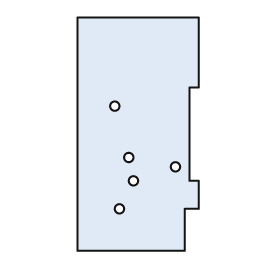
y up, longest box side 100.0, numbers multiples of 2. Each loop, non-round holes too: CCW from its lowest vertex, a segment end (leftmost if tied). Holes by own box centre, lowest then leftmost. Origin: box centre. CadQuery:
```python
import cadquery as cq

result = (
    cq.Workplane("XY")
    .moveTo(-26.0, -50.0)
    .lineTo(20.0, -50.0)
    .lineTo(20.0, -32.0)
    .lineTo(26.0, -32.0)
    .lineTo(26.0, -20.0)
    .lineTo(22.0, -20.0)
    .lineTo(22.0, 20.0)
    .lineTo(26.0, 20.0)
    .lineTo(26.0, 50.0)
    .lineTo(-26.0, 50.0)
    .close()
    .moveTo(-8.0, -32.0)
    .circle(2.0)
    .moveTo(-2.0, -20.0)
    .circle(2.0)
    .moveTo(16.0, -14.0)
    .circle(2.0)
    .moveTo(-4.0, -10.0)
    .circle(2.0)
    .moveTo(-10.0, 12.0)
    .circle(2.0)
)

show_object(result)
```